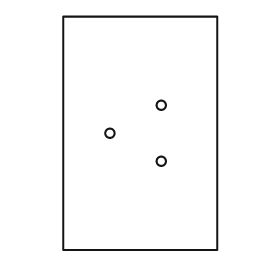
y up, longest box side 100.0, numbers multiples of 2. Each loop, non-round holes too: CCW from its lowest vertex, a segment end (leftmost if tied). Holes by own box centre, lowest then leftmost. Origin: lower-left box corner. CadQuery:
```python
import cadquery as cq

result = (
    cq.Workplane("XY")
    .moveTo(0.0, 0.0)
    .lineTo(66.0, 0.0)
    .lineTo(66.0, 100.0)
    .lineTo(0.0, 100.0)
    .close()
    .moveTo(42.0, 38.0)
    .circle(2.0)
    .moveTo(20.0, 50.0)
    .circle(2.0)
    .moveTo(42.0, 62.0)
    .circle(2.0)
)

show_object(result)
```